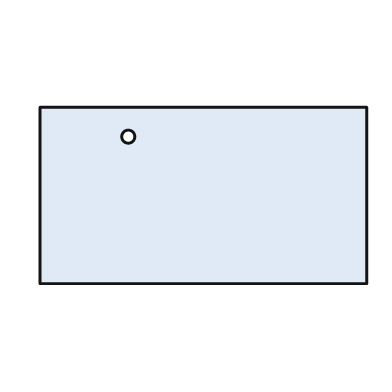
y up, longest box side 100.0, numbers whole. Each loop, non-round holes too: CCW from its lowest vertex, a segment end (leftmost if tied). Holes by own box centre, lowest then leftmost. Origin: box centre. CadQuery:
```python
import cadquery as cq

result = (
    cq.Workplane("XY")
    .moveTo(-50.0, -27.0)
    .lineTo(50.0, -27.0)
    .lineTo(50.0, 27.0)
    .lineTo(-50.0, 27.0)
    .close()
    .moveTo(-23.0, 18.0)
    .circle(2.0)
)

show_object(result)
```